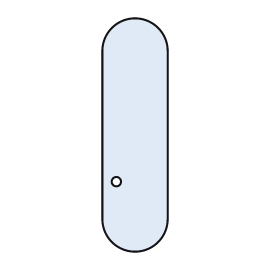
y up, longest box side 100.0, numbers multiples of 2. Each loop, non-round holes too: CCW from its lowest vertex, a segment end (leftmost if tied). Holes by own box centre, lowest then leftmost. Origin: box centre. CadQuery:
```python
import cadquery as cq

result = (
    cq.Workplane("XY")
    .moveTo(-14.0, -36.0)
    .threePointArc((0.0, -50.0), (14.0, -36.0))
    .lineTo(14.0, 36.0)
    .threePointArc((0.0, 50.0), (-14.0, 36.0))
    .close()
    .moveTo(-8.0, -20.0)
    .circle(2.0)
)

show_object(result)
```